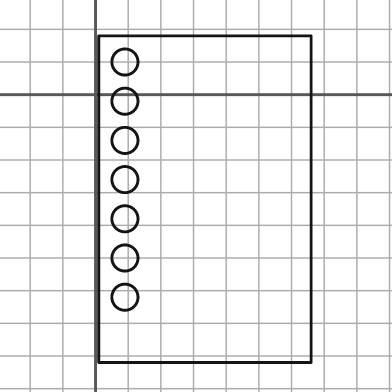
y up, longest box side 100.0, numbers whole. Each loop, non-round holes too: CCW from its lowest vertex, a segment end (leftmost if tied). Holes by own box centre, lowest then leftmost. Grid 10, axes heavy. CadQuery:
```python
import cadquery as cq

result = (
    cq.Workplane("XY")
    .moveTo(1.0, -82.0)
    .lineTo(66.0, -82.0)
    .lineTo(66.0, 18.0)
    .lineTo(1.0, 18.0)
    .close()
    .moveTo(9.0, -62.0)
    .circle(4.0)
    .moveTo(9.0, -50.0)
    .circle(4.0)
    .moveTo(9.0, -38.0)
    .circle(4.0)
    .moveTo(9.0, -26.0)
    .circle(4.0)
    .moveTo(9.0, -14.0)
    .circle(4.0)
    .moveTo(9.0, -2.0)
    .circle(4.0)
    .moveTo(9.0, 10.0)
    .circle(4.0)
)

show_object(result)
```